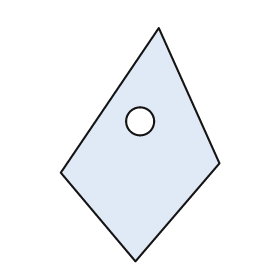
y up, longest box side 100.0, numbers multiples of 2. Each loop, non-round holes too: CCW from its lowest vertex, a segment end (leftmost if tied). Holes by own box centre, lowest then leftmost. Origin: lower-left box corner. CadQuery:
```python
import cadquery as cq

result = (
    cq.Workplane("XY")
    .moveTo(32.0, 0.0)
    .lineTo(68.0, 42.0)
    .lineTo(42.0, 100.0)
    .lineTo(0.0, 38.0)
    .close()
    .moveTo(34.0, 60.0)
    .circle(6.0)
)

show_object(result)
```